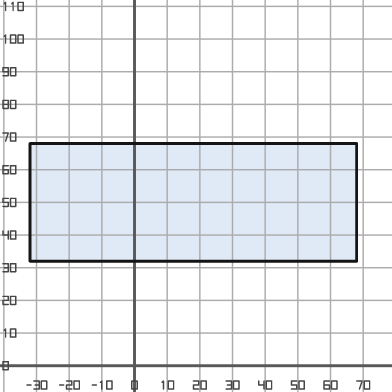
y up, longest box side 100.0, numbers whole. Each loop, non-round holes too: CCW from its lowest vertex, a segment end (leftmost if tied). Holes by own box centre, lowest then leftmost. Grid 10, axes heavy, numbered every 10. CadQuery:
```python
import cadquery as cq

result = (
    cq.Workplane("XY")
    .moveTo(-32.0, 32.0)
    .lineTo(68.0, 32.0)
    .lineTo(68.0, 68.0)
    .lineTo(-32.0, 68.0)
    .close()
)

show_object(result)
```